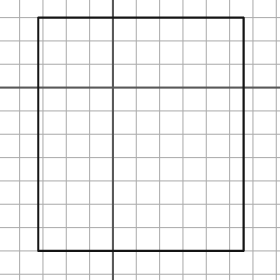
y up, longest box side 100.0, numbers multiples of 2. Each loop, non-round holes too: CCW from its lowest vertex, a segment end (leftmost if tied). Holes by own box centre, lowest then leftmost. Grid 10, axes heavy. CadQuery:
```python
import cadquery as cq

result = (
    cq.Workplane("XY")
    .moveTo(-32.0, -70.0)
    .lineTo(56.0, -70.0)
    .lineTo(56.0, 30.0)
    .lineTo(-32.0, 30.0)
    .close()
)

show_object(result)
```